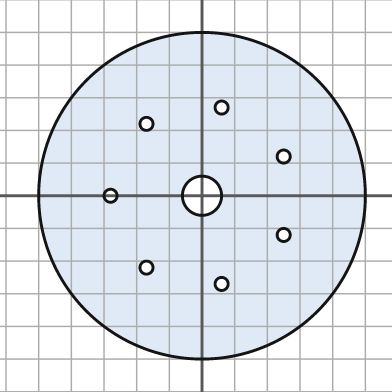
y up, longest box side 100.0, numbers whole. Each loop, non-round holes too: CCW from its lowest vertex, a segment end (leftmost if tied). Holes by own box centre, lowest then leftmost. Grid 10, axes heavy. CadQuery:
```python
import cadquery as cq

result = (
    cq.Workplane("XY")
    .moveTo(0.0, 0.0)
    .circle(50.0)
    .moveTo(6.0, -27.0)
    .circle(2.0)
    .moveTo(-17.0, -22.0)
    .circle(2.0)
    .moveTo(25.0, -12.0)
    .circle(2.0)
    .moveTo(-28.0, 0.0)
    .circle(2.0)
    .moveTo(0.0, 0.0)
    .circle(6.0)
    .moveTo(25.0, 12.0)
    .circle(2.0)
    .moveTo(-17.0, 22.0)
    .circle(2.0)
    .moveTo(6.0, 27.0)
    .circle(2.0)
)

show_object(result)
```